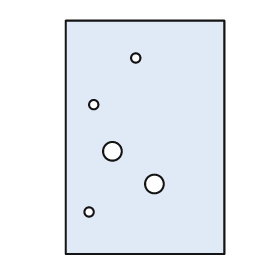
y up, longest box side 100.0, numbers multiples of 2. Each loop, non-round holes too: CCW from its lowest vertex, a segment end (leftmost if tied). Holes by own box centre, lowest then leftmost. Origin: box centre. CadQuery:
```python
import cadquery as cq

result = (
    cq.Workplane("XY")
    .moveTo(-34.0, -50.0)
    .lineTo(34.0, -50.0)
    .lineTo(34.0, 50.0)
    .lineTo(-34.0, 50.0)
    .close()
    .moveTo(-24.0, -32.0)
    .circle(2.0)
    .moveTo(4.0, -20.0)
    .circle(4.0)
    .moveTo(-14.0, -6.0)
    .circle(4.0)
    .moveTo(-22.0, 14.0)
    .circle(2.0)
    .moveTo(-4.0, 34.0)
    .circle(2.0)
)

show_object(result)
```